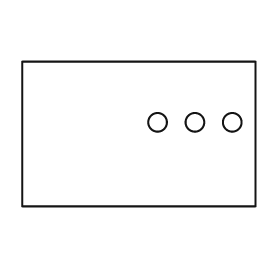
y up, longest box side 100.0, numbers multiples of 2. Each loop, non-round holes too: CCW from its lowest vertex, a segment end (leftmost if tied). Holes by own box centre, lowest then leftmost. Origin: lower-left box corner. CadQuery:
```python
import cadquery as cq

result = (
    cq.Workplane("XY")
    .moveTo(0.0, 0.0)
    .lineTo(100.0, 0.0)
    .lineTo(100.0, 62.0)
    .lineTo(0.0, 62.0)
    .close()
    .moveTo(58.0, 36.0)
    .circle(4.0)
    .moveTo(74.0, 36.0)
    .circle(4.0)
    .moveTo(90.0, 36.0)
    .circle(4.0)
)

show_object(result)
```